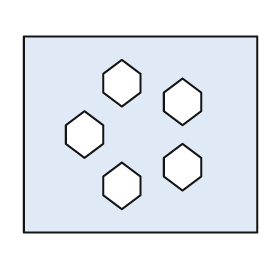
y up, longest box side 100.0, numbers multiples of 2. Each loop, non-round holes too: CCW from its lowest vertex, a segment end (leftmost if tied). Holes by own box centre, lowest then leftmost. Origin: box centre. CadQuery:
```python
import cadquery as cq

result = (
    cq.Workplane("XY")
    .moveTo(-50.0, -42.0)
    .lineTo(50.0, -42.0)
    .lineTo(50.0, 42.0)
    .lineTo(-50.0, 42.0)
    .close()
    .moveTo(-8.0, -32.0)
    .lineTo(0.0, -26.0)
    .lineTo(0.0, -18.0)
    .lineTo(-8.0, -12.0)
    .lineTo(-16.0, -18.0)
    .lineTo(-16.0, -26.0)
    .close()
    .moveTo(18.0, -24.0)
    .lineTo(26.0, -18.0)
    .lineTo(26.0, -10.0)
    .lineTo(18.0, -4.0)
    .lineTo(10.0, -10.0)
    .lineTo(10.0, -18.0)
    .close()
    .moveTo(-24.0, -10.0)
    .lineTo(-16.0, -4.0)
    .lineTo(-16.0, 4.0)
    .lineTo(-24.0, 10.0)
    .lineTo(-32.0, 4.0)
    .lineTo(-32.0, -4.0)
    .close()
    .moveTo(18.0, 4.0)
    .lineTo(26.0, 10.0)
    .lineTo(26.0, 18.0)
    .lineTo(18.0, 24.0)
    .lineTo(10.0, 18.0)
    .lineTo(10.0, 10.0)
    .close()
    .moveTo(-8.0, 12.0)
    .lineTo(0.0, 18.0)
    .lineTo(0.0, 26.0)
    .lineTo(-8.0, 32.0)
    .lineTo(-16.0, 26.0)
    .lineTo(-16.0, 18.0)
    .close()
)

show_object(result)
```